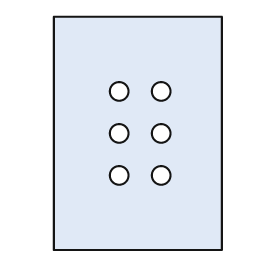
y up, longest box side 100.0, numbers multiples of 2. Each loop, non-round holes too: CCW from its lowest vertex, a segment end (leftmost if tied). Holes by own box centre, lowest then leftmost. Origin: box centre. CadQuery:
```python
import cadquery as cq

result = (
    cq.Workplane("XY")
    .moveTo(-36.0, -50.0)
    .lineTo(36.0, -50.0)
    .lineTo(36.0, 50.0)
    .lineTo(-36.0, 50.0)
    .close()
    .moveTo(-8.0, -18.0)
    .circle(4.0)
    .moveTo(10.0, -18.0)
    .circle(4.0)
    .moveTo(-8.0, 0.0)
    .circle(4.0)
    .moveTo(10.0, 0.0)
    .circle(4.0)
    .moveTo(-8.0, 18.0)
    .circle(4.0)
    .moveTo(10.0, 18.0)
    .circle(4.0)
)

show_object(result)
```